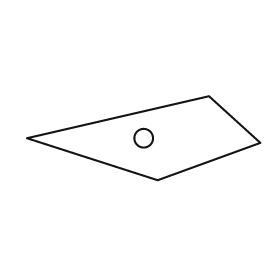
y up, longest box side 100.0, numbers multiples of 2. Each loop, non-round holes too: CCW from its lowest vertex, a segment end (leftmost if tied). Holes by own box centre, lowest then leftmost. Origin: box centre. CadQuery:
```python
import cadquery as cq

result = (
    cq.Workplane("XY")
    .moveTo(6.0, -18.0)
    .lineTo(50.0, -2.0)
    .lineTo(28.0, 18.0)
    .lineTo(-50.0, 0.0)
    .close()
    .moveTo(0.0, 0.0)
    .circle(4.0)
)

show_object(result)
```